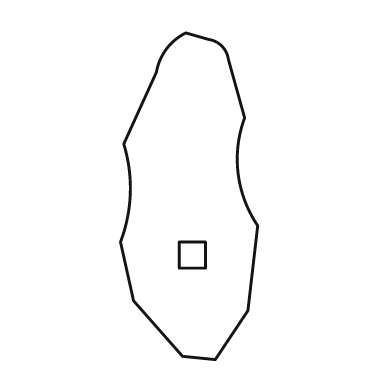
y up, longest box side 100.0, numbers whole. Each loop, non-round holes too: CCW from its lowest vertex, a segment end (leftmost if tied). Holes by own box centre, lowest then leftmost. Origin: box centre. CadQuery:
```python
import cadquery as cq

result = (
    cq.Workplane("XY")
    .moveTo(8.0, -50.0)
    .lineTo(18.0, -35.0)
    .lineTo(21.0, -9.0)
    .threePointArc((15.0, 7.0), (17.0, 24.0))
    .lineTo(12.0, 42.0)
    .threePointArc((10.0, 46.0), (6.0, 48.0))
    .lineTo(-1.0, 50.0)
    .threePointArc((-7.0, 45.0), (-10.0, 38.0))
    .lineTo(-20.0, 16.0)
    .threePointArc((-18.0, 1.0), (-21.0, -14.0))
    .lineTo(-17.0, -32.0)
    .lineTo(-2.0, -49.0)
    .close()
    .moveTo(-3.0, -22.0)
    .lineTo(5.0, -22.0)
    .lineTo(5.0, -14.0)
    .lineTo(-3.0, -14.0)
    .close()
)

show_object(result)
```